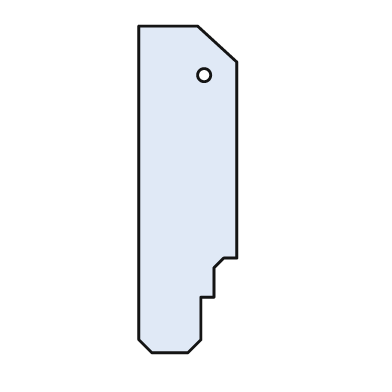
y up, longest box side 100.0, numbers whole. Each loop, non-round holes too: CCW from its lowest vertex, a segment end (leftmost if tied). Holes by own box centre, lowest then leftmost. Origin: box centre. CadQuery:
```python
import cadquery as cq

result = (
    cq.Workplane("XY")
    .moveTo(-11.0, -50.0)
    .lineTo(0.0, -50.0)
    .lineTo(4.0, -46.0)
    .lineTo(4.0, -33.0)
    .lineTo(8.0, -33.0)
    .lineTo(8.0, -24.0)
    .lineTo(11.0, -21.0)
    .lineTo(15.0, -21.0)
    .lineTo(15.0, 39.0)
    .lineTo(3.0, 50.0)
    .lineTo(-15.0, 50.0)
    .lineTo(-15.0, -46.0)
    .close()
    .moveTo(5.0, 35.0)
    .circle(2.0)
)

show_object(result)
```